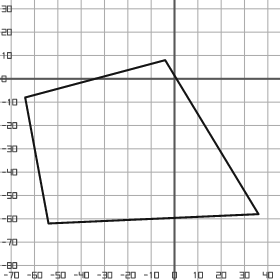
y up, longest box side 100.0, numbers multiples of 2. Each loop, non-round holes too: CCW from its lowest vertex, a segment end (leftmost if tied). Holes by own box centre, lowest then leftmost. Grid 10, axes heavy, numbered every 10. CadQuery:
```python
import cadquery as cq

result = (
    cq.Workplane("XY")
    .moveTo(-54.0, -62.0)
    .lineTo(36.0, -58.0)
    .lineTo(-4.0, 8.0)
    .lineTo(-64.0, -8.0)
    .close()
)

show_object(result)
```